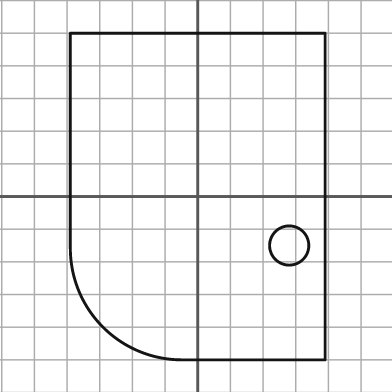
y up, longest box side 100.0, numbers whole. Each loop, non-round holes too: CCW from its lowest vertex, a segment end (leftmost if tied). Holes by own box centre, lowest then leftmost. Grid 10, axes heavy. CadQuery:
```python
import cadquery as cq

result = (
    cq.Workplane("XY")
    .moveTo(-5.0, -50.0)
    .lineTo(39.0, -50.0)
    .lineTo(39.0, 50.0)
    .lineTo(-39.0, 50.0)
    .lineTo(-39.0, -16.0)
    .threePointArc((-29.0, -40.0), (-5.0, -50.0))
    .close()
    .moveTo(28.0, -15.0)
    .circle(6.0)
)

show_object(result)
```